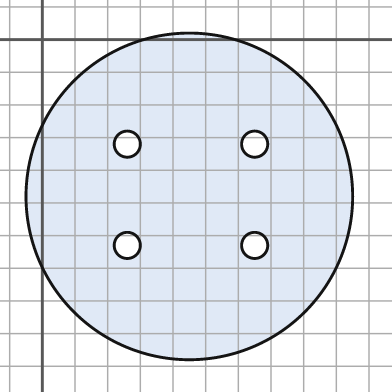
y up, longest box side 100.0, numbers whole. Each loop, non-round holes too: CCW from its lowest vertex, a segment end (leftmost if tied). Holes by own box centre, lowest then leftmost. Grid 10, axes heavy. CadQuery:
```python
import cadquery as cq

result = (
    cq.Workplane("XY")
    .moveTo(45.0, -48.0)
    .circle(50.0)
    .moveTo(26.0, -63.0)
    .circle(4.0)
    .moveTo(65.0, -63.0)
    .circle(4.0)
    .moveTo(26.0, -32.0)
    .circle(4.0)
    .moveTo(65.0, -32.0)
    .circle(4.0)
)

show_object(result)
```